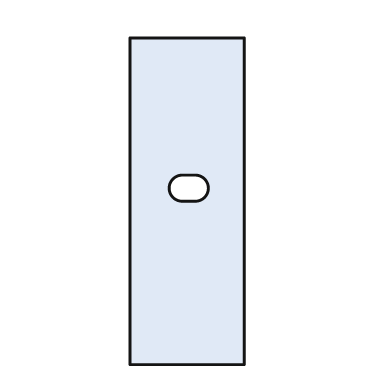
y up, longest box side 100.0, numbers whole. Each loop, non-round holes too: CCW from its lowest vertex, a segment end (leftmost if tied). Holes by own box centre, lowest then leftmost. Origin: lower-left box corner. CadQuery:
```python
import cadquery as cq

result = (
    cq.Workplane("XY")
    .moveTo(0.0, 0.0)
    .lineTo(35.0, 0.0)
    .lineTo(35.0, 100.0)
    .lineTo(0.0, 100.0)
    .close()
    .moveTo(16.0, 50.0)
    .lineTo(20.0, 50.0)
    .threePointArc((24.0, 54.0), (20.0, 58.0))
    .lineTo(16.0, 58.0)
    .threePointArc((12.0, 54.0), (16.0, 50.0))
    .close()
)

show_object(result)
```